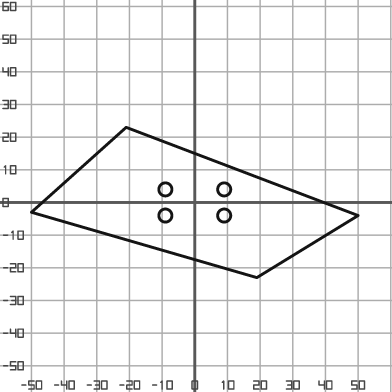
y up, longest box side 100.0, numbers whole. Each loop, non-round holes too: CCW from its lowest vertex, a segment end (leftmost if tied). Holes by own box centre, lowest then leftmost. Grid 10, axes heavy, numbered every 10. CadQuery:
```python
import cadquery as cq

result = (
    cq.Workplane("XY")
    .moveTo(19.0, -23.0)
    .lineTo(50.0, -4.0)
    .lineTo(-21.0, 23.0)
    .lineTo(-50.0, -3.0)
    .close()
    .moveTo(-9.0, -4.0)
    .circle(2.0)
    .moveTo(9.0, -4.0)
    .circle(2.0)
    .moveTo(-9.0, 4.0)
    .circle(2.0)
    .moveTo(9.0, 4.0)
    .circle(2.0)
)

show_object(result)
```